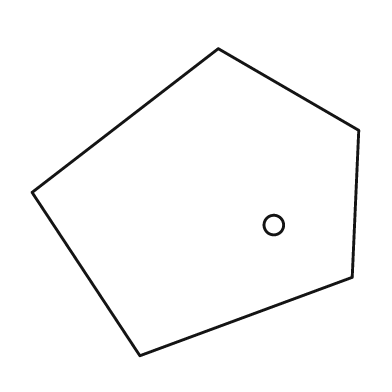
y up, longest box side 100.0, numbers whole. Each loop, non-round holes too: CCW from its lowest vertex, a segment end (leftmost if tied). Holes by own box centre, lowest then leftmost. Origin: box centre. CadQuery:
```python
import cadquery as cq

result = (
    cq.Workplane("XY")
    .moveTo(-17.0, -47.0)
    .lineTo(48.0, -23.0)
    .lineTo(50.0, 22.0)
    .lineTo(7.0, 47.0)
    .lineTo(-50.0, 3.0)
    .close()
    .moveTo(24.0, -7.0)
    .circle(3.0)
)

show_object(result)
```